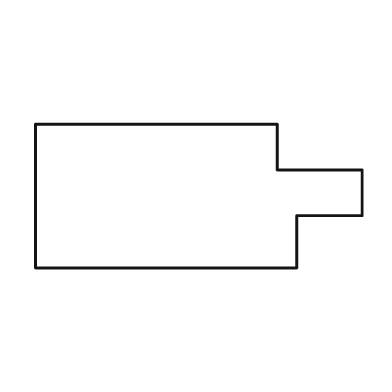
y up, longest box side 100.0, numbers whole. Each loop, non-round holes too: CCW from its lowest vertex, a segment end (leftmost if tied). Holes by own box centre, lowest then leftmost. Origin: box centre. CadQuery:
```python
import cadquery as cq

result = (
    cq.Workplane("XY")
    .moveTo(-50.0, -22.0)
    .lineTo(30.0, -22.0)
    .lineTo(30.0, -6.0)
    .lineTo(50.0, -6.0)
    .lineTo(50.0, 8.0)
    .lineTo(24.0, 8.0)
    .lineTo(24.0, 22.0)
    .lineTo(-50.0, 22.0)
    .close()
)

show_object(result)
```